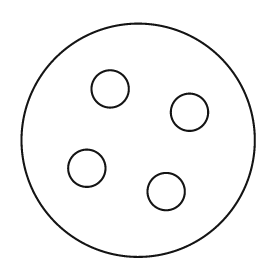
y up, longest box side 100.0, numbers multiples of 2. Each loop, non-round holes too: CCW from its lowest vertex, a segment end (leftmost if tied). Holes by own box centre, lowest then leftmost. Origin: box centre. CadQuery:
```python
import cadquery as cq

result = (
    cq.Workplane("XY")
    .moveTo(0.0, 0.0)
    .circle(50.0)
    .moveTo(12.0, -22.0)
    .circle(8.0)
    .moveTo(-22.0, -12.0)
    .circle(8.0)
    .moveTo(22.0, 12.0)
    .circle(8.0)
    .moveTo(-12.0, 22.0)
    .circle(8.0)
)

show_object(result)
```